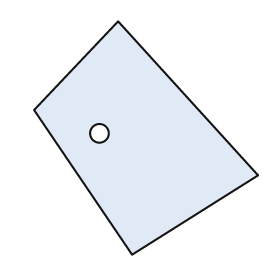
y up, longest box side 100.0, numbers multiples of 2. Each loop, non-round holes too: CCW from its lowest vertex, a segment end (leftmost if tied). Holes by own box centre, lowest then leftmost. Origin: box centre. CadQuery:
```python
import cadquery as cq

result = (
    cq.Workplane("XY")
    .moveTo(-6.0, -50.0)
    .lineTo(48.0, -16.0)
    .lineTo(-12.0, 50.0)
    .lineTo(-48.0, 12.0)
    .close()
    .moveTo(-20.0, 2.0)
    .circle(4.0)
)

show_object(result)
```